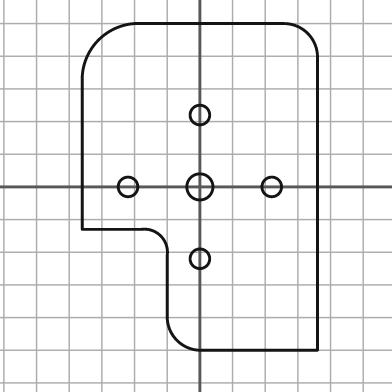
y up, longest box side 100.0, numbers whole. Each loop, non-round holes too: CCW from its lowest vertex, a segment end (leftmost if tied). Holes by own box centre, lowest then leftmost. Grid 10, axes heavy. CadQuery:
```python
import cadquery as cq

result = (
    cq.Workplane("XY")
    .moveTo(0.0, -50.0)
    .lineTo(36.0, -50.0)
    .lineTo(36.0, 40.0)
    .threePointArc((33.0, 47.0), (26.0, 50.0))
    .lineTo(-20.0, 50.0)
    .threePointArc((-31.0, 45.0), (-36.0, 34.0))
    .lineTo(-36.0, -13.0)
    .lineTo(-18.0, -13.0)
    .threePointArc((-12.0, -15.0), (-10.0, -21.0))
    .lineTo(-10.0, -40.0)
    .threePointArc((-7.0, -47.0), (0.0, -50.0))
    .close()
    .moveTo(0.0, -22.0)
    .circle(3.0)
    .moveTo(-22.0, 0.0)
    .circle(3.0)
    .moveTo(0.0, 0.0)
    .circle(4.0)
    .moveTo(22.0, 0.0)
    .circle(3.0)
    .moveTo(0.0, 22.0)
    .circle(3.0)
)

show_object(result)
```